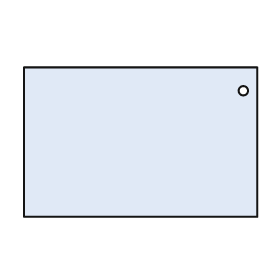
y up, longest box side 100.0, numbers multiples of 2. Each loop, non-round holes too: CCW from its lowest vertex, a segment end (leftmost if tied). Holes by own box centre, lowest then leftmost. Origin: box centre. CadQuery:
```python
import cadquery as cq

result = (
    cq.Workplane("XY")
    .moveTo(-50.0, -32.0)
    .lineTo(50.0, -32.0)
    .lineTo(50.0, 32.0)
    .lineTo(-50.0, 32.0)
    .close()
    .moveTo(44.0, 22.0)
    .circle(2.0)
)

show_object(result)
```